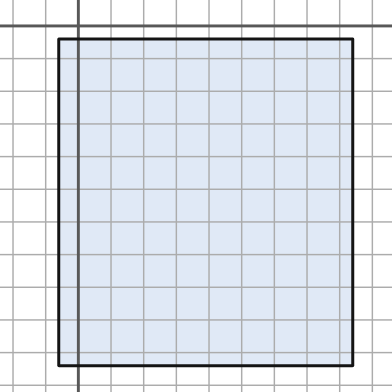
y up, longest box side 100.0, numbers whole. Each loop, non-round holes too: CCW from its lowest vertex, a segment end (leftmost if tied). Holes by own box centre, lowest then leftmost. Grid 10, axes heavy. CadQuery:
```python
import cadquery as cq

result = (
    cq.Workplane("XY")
    .moveTo(-6.0, -104.0)
    .lineTo(84.0, -104.0)
    .lineTo(84.0, -4.0)
    .lineTo(-6.0, -4.0)
    .close()
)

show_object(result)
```